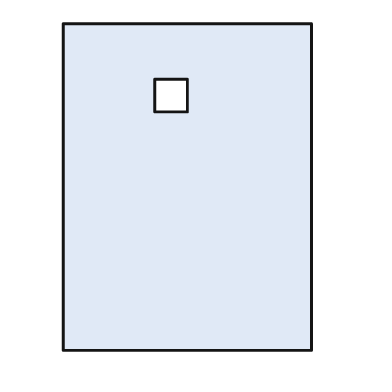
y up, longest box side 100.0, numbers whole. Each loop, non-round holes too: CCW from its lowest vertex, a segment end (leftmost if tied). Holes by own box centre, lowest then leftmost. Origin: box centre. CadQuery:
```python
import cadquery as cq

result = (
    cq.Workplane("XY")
    .moveTo(-38.0, -50.0)
    .lineTo(38.0, -50.0)
    .lineTo(38.0, 50.0)
    .lineTo(-38.0, 50.0)
    .close()
    .moveTo(-10.0, 23.0)
    .lineTo(0.0, 23.0)
    .lineTo(0.0, 33.0)
    .lineTo(-10.0, 33.0)
    .close()
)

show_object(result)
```